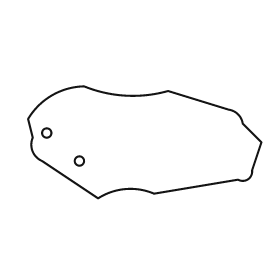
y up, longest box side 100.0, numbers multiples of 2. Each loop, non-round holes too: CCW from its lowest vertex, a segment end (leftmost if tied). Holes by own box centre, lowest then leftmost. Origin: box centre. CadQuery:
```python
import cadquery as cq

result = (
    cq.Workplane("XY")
    .moveTo(-20.0, -24.0)
    .threePointArc((-8.0, -20.0), (4.0, -22.0))
    .lineTo(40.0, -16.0)
    .threePointArc((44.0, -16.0), (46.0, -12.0))
    .lineTo(50.0, 0.0)
    .lineTo(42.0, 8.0)
    .threePointArc((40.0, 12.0), (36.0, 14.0))
    .lineTo(10.0, 22.0)
    .threePointArc((-8.0, 20.0), (-26.0, 24.0))
    .threePointArc((-40.0, 20.0), (-50.0, 10.0))
    .lineTo(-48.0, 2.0)
    .threePointArc((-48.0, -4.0), (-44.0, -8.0))
    .close()
    .moveTo(-28.0, -8.0)
    .circle(2.0)
    .moveTo(-42.0, 4.0)
    .circle(2.0)
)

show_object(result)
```